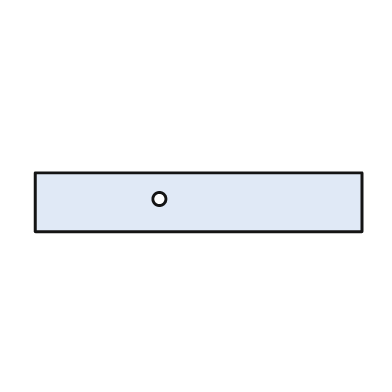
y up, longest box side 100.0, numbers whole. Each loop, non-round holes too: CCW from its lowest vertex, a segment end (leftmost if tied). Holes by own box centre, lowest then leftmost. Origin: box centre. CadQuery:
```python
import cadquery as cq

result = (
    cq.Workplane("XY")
    .moveTo(-50.0, -9.0)
    .lineTo(50.0, -9.0)
    .lineTo(50.0, 9.0)
    .lineTo(-50.0, 9.0)
    .close()
    .moveTo(-12.0, 1.0)
    .circle(2.0)
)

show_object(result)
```